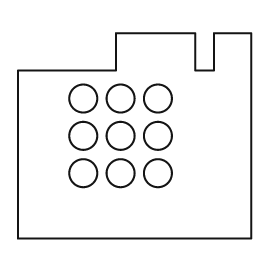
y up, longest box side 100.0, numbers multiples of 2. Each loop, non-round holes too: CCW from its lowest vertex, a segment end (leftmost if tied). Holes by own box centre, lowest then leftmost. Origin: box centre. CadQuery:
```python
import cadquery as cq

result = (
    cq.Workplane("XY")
    .moveTo(-50.0, -44.0)
    .lineTo(50.0, -44.0)
    .lineTo(50.0, 44.0)
    .lineTo(34.0, 44.0)
    .lineTo(34.0, 28.0)
    .lineTo(26.0, 28.0)
    .lineTo(26.0, 44.0)
    .lineTo(-8.0, 44.0)
    .lineTo(-8.0, 28.0)
    .lineTo(-50.0, 28.0)
    .close()
    .moveTo(-22.0, -16.0)
    .circle(6.0)
    .moveTo(-6.0, -16.0)
    .circle(6.0)
    .moveTo(10.0, -16.0)
    .circle(6.0)
    .moveTo(-22.0, 0.0)
    .circle(6.0)
    .moveTo(-6.0, 0.0)
    .circle(6.0)
    .moveTo(10.0, 0.0)
    .circle(6.0)
    .moveTo(-22.0, 16.0)
    .circle(6.0)
    .moveTo(-6.0, 16.0)
    .circle(6.0)
    .moveTo(10.0, 16.0)
    .circle(6.0)
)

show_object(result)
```